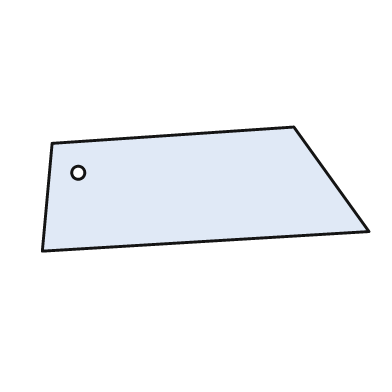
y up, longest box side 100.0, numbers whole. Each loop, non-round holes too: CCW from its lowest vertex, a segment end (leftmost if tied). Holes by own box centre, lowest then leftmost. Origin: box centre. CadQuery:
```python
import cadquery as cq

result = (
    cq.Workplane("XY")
    .moveTo(-50.0, -19.0)
    .lineTo(50.0, -13.0)
    .lineTo(27.0, 19.0)
    .lineTo(-47.0, 14.0)
    .close()
    .moveTo(-39.0, 5.0)
    .circle(2.0)
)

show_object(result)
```